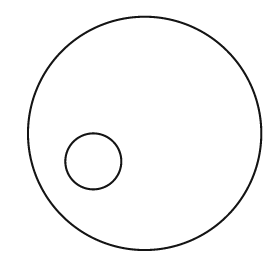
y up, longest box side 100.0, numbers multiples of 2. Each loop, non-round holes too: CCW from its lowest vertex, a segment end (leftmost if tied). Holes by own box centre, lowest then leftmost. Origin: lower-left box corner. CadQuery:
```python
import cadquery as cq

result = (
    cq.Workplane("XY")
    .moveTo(50.0, 50.0)
    .circle(50.0)
    .moveTo(28.0, 38.0)
    .circle(12.0)
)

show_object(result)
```